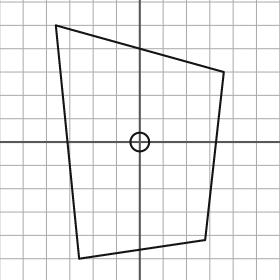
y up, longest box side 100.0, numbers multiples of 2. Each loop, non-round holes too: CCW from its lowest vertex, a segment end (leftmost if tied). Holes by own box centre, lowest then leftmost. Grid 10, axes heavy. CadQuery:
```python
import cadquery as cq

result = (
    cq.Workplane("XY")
    .moveTo(-26.0, -50.0)
    .lineTo(28.0, -42.0)
    .lineTo(36.0, 30.0)
    .lineTo(-36.0, 50.0)
    .close()
    .moveTo(0.0, 0.0)
    .circle(4.0)
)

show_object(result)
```